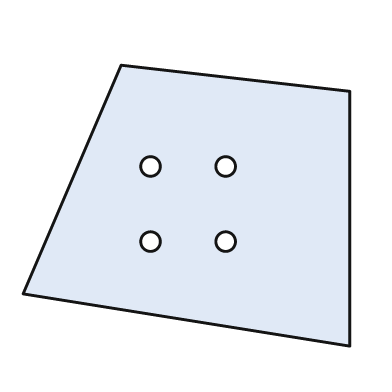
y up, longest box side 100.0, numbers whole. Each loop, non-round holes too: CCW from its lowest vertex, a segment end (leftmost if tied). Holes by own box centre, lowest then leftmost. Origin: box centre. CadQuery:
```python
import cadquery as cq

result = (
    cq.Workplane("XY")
    .moveTo(50.0, -43.0)
    .lineTo(50.0, 35.0)
    .lineTo(-20.0, 43.0)
    .lineTo(-50.0, -27.0)
    .close()
    .moveTo(-11.0, -11.0)
    .circle(3.0)
    .moveTo(12.0, -11.0)
    .circle(3.0)
    .moveTo(-11.0, 12.0)
    .circle(3.0)
    .moveTo(12.0, 12.0)
    .circle(3.0)
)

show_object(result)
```